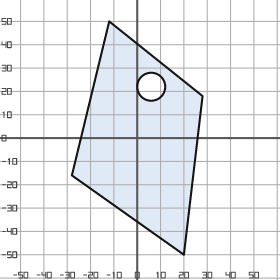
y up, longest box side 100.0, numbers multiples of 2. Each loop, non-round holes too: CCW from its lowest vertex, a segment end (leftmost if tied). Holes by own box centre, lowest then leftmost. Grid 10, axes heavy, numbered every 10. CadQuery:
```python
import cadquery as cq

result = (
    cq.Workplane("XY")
    .moveTo(20.0, -50.0)
    .lineTo(28.0, 18.0)
    .lineTo(-12.0, 50.0)
    .lineTo(-28.0, -16.0)
    .close()
    .moveTo(6.0, 22.0)
    .circle(6.0)
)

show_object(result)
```